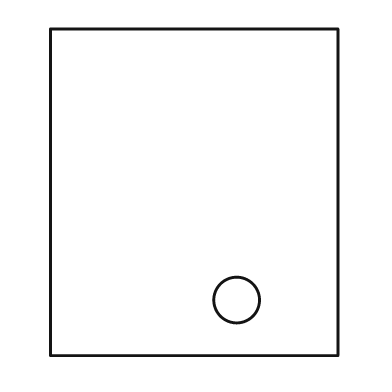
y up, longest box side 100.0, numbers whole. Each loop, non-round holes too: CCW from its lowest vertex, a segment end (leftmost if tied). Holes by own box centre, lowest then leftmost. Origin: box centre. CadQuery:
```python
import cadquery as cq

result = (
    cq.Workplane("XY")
    .moveTo(-44.0, -50.0)
    .lineTo(44.0, -50.0)
    .lineTo(44.0, 50.0)
    .lineTo(-44.0, 50.0)
    .close()
    .moveTo(13.0, -33.0)
    .circle(7.0)
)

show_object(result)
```